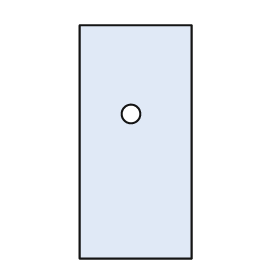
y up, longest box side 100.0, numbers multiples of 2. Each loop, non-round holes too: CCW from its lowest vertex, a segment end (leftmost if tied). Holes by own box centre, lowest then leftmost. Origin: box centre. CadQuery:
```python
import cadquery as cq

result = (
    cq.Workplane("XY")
    .moveTo(-24.0, -50.0)
    .lineTo(24.0, -50.0)
    .lineTo(24.0, 50.0)
    .lineTo(-24.0, 50.0)
    .close()
    .moveTo(-2.0, 12.0)
    .circle(4.0)
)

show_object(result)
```